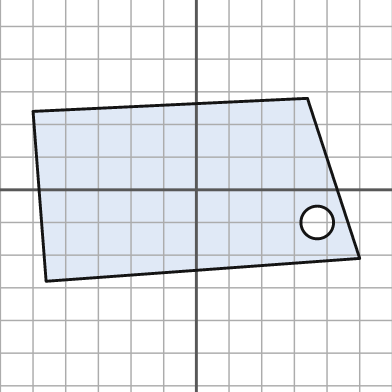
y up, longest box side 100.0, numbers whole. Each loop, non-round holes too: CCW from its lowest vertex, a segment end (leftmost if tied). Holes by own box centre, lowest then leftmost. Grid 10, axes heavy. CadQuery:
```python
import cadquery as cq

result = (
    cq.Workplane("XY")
    .moveTo(-46.0, -28.0)
    .lineTo(50.0, -21.0)
    .lineTo(34.0, 28.0)
    .lineTo(-50.0, 24.0)
    .close()
    .moveTo(37.0, -10.0)
    .circle(5.0)
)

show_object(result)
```